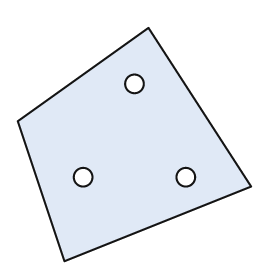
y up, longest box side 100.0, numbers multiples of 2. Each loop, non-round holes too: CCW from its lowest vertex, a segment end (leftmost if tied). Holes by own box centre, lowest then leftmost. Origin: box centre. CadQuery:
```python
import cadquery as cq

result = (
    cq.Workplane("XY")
    .moveTo(-30.0, -50.0)
    .lineTo(50.0, -18.0)
    .lineTo(6.0, 50.0)
    .lineTo(-50.0, 10.0)
    .close()
    .moveTo(-22.0, -14.0)
    .circle(4.0)
    .moveTo(22.0, -14.0)
    .circle(4.0)
    .moveTo(0.0, 26.0)
    .circle(4.0)
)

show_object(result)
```